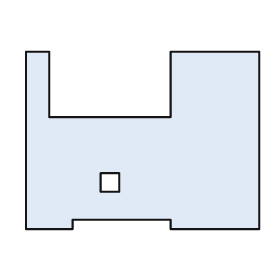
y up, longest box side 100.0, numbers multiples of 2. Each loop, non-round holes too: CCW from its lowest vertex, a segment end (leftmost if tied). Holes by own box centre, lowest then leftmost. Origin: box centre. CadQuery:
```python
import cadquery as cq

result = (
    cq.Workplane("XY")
    .moveTo(-50.0, -38.0)
    .lineTo(-30.0, -38.0)
    .lineTo(-30.0, -34.0)
    .lineTo(12.0, -34.0)
    .lineTo(12.0, -38.0)
    .lineTo(50.0, -38.0)
    .lineTo(50.0, 38.0)
    .lineTo(12.0, 38.0)
    .lineTo(12.0, 10.0)
    .lineTo(-40.0, 10.0)
    .lineTo(-40.0, 38.0)
    .lineTo(-50.0, 38.0)
    .close()
    .moveTo(-18.0, -22.0)
    .lineTo(-10.0, -22.0)
    .lineTo(-10.0, -14.0)
    .lineTo(-18.0, -14.0)
    .close()
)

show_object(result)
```